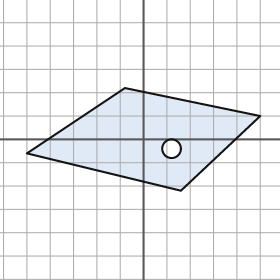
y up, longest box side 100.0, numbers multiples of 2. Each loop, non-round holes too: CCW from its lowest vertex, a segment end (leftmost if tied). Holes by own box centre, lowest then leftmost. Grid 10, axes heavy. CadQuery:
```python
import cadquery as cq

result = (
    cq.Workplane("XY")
    .moveTo(16.0, -22.0)
    .lineTo(50.0, 10.0)
    .lineTo(-8.0, 22.0)
    .lineTo(-50.0, -6.0)
    .close()
    .moveTo(12.0, -4.0)
    .circle(4.0)
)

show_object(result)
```